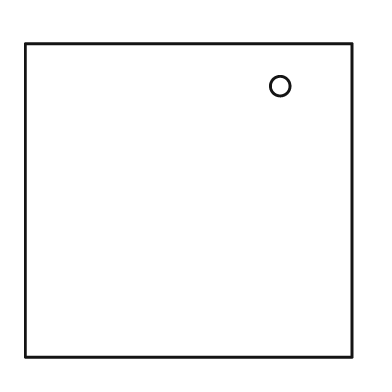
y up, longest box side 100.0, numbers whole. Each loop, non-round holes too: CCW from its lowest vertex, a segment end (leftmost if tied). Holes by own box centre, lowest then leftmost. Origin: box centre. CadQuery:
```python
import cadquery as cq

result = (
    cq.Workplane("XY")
    .moveTo(-50.0, -48.0)
    .lineTo(50.0, -48.0)
    .lineTo(50.0, 48.0)
    .lineTo(-50.0, 48.0)
    .close()
    .moveTo(28.0, 35.0)
    .circle(3.0)
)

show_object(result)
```